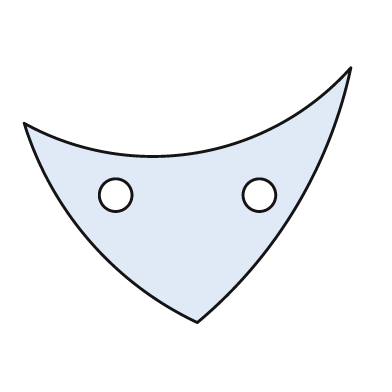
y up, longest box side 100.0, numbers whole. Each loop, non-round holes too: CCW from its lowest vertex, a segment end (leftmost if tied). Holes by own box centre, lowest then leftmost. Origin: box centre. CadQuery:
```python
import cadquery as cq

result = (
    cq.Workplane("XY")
    .moveTo(3.0, -39.0)
    .threePointArc((33.0, -4.0), (50.0, 39.0))
    .threePointArc((3.0, 13.0), (-50.0, 22.0))
    .threePointArc((-30.0, -14.0), (3.0, -39.0))
    .close()
    .moveTo(-22.0, 0.0)
    .circle(5.0)
    .moveTo(22.0, 0.0)
    .circle(5.0)
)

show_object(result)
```